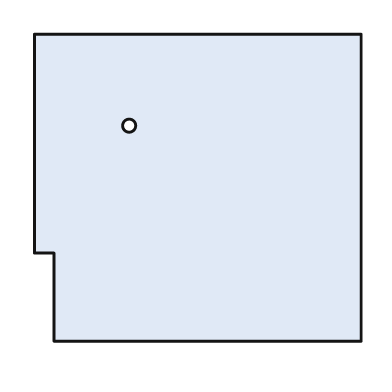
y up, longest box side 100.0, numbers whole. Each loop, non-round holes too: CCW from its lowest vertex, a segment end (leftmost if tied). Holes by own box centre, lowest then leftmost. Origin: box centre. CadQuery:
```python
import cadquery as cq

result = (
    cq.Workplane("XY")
    .moveTo(-44.0, -47.0)
    .lineTo(50.0, -47.0)
    .lineTo(50.0, 47.0)
    .lineTo(-50.0, 47.0)
    .lineTo(-50.0, -20.0)
    .lineTo(-44.0, -20.0)
    .close()
    .moveTo(-21.0, 19.0)
    .circle(2.0)
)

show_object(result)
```